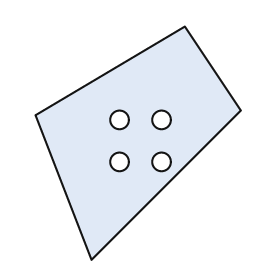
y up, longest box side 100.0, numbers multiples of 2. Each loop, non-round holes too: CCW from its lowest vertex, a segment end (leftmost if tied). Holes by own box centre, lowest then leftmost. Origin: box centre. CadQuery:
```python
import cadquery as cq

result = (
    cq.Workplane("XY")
    .moveTo(-20.0, -50.0)
    .lineTo(44.0, 14.0)
    .lineTo(20.0, 50.0)
    .lineTo(-44.0, 12.0)
    .close()
    .moveTo(-8.0, -8.0)
    .circle(4.0)
    .moveTo(10.0, -8.0)
    .circle(4.0)
    .moveTo(-8.0, 10.0)
    .circle(4.0)
    .moveTo(10.0, 10.0)
    .circle(4.0)
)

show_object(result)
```